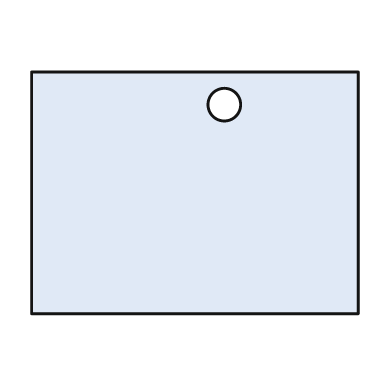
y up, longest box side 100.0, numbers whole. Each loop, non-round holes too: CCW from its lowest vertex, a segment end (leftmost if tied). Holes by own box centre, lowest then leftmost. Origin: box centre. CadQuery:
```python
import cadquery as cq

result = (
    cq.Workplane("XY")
    .moveTo(-50.0, -37.0)
    .lineTo(50.0, -37.0)
    .lineTo(50.0, 37.0)
    .lineTo(-50.0, 37.0)
    .close()
    .moveTo(9.0, 27.0)
    .circle(5.0)
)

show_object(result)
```